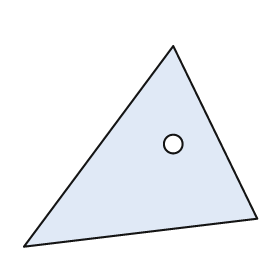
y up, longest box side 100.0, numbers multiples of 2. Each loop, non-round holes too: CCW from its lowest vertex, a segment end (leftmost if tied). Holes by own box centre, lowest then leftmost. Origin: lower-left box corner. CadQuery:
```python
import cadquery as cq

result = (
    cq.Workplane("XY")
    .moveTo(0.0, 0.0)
    .lineTo(100.0, 12.0)
    .lineTo(64.0, 86.0)
    .close()
    .moveTo(64.0, 44.0)
    .circle(4.0)
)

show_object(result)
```